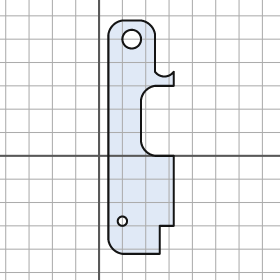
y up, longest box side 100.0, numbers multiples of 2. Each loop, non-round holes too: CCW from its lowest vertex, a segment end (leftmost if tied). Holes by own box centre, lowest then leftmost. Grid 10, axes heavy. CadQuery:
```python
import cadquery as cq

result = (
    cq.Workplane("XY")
    .moveTo(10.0, -42.0)
    .lineTo(26.0, -42.0)
    .lineTo(26.0, -30.0)
    .lineTo(32.0, -30.0)
    .lineTo(32.0, 0.0)
    .lineTo(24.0, 0.0)
    .threePointArc((20.0, 2.0), (18.0, 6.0))
    .lineTo(18.0, 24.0)
    .threePointArc((20.0, 28.0), (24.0, 30.0))
    .lineTo(32.0, 30.0)
    .lineTo(32.0, 36.0)
    .threePointArc((28.0, 34.0), (24.0, 36.0))
    .lineTo(24.0, 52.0)
    .threePointArc((22.0, 56.0), (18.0, 58.0))
    .lineTo(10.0, 58.0)
    .threePointArc((6.0, 56.0), (4.0, 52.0))
    .lineTo(4.0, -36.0)
    .threePointArc((6.0, -40.0), (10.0, -42.0))
    .close()
    .moveTo(10.0, -28.0)
    .circle(2.0)
    .moveTo(14.0, 50.0)
    .circle(4.0)
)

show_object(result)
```